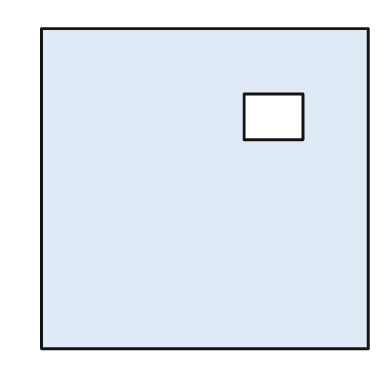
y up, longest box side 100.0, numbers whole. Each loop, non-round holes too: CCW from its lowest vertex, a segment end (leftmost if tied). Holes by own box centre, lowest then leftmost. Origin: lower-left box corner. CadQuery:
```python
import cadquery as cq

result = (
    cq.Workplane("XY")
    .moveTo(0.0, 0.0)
    .lineTo(100.0, 0.0)
    .lineTo(100.0, 98.0)
    .lineTo(0.0, 98.0)
    .close()
    .moveTo(62.0, 64.0)
    .lineTo(80.0, 64.0)
    .lineTo(80.0, 78.0)
    .lineTo(62.0, 78.0)
    .close()
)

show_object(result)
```